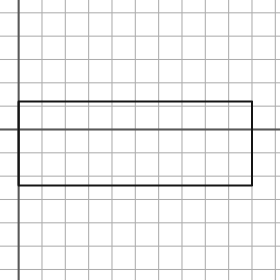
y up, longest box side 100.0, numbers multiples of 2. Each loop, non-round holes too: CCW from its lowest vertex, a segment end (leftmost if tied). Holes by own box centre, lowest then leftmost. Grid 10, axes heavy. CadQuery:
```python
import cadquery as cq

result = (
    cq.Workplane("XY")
    .moveTo(0.0, -24.0)
    .lineTo(100.0, -24.0)
    .lineTo(100.0, 12.0)
    .lineTo(0.0, 12.0)
    .close()
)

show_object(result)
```